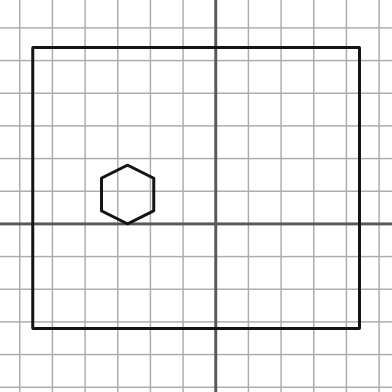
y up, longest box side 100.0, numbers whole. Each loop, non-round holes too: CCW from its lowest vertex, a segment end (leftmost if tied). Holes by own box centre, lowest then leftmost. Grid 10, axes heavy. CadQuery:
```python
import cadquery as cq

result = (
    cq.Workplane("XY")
    .moveTo(-56.0, -32.0)
    .lineTo(44.0, -32.0)
    .lineTo(44.0, 54.0)
    .lineTo(-56.0, 54.0)
    .close()
    .moveTo(-27.0, 0.0)
    .lineTo(-19.0, 4.0)
    .lineTo(-19.0, 14.0)
    .lineTo(-27.0, 18.0)
    .lineTo(-35.0, 14.0)
    .lineTo(-35.0, 4.0)
    .close()
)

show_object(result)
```